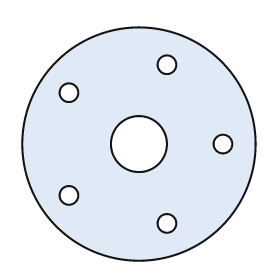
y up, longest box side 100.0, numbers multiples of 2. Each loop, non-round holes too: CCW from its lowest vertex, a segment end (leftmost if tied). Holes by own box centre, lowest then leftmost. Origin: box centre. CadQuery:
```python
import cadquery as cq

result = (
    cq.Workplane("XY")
    .moveTo(0.0, 0.0)
    .circle(50.0)
    .moveTo(12.0, -34.0)
    .circle(4.0)
    .moveTo(-30.0, -22.0)
    .circle(4.0)
    .moveTo(0.0, 0.0)
    .circle(12.0)
    .moveTo(36.0, 0.0)
    .circle(4.0)
    .moveTo(-30.0, 22.0)
    .circle(4.0)
    .moveTo(12.0, 34.0)
    .circle(4.0)
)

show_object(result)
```